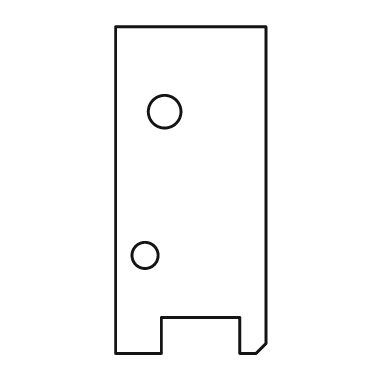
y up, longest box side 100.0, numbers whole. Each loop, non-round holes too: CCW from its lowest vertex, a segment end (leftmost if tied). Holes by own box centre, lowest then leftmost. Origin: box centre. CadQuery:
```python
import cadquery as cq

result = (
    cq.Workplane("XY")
    .moveTo(-23.0, -50.0)
    .lineTo(-9.0, -50.0)
    .lineTo(-9.0, -39.0)
    .lineTo(15.0, -39.0)
    .lineTo(15.0, -50.0)
    .lineTo(20.0, -50.0)
    .lineTo(23.0, -47.0)
    .lineTo(23.0, 50.0)
    .lineTo(-23.0, 50.0)
    .close()
    .moveTo(-14.0, -20.0)
    .circle(4.0)
    .moveTo(-8.0, 24.0)
    .circle(5.0)
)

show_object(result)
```